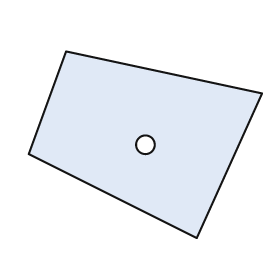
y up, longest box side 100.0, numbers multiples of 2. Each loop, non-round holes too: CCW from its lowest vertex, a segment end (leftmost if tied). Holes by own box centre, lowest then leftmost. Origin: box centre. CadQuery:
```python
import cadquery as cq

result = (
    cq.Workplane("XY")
    .moveTo(22.0, -40.0)
    .lineTo(50.0, 22.0)
    .lineTo(-34.0, 40.0)
    .lineTo(-50.0, -4.0)
    .close()
    .moveTo(0.0, 0.0)
    .circle(4.0)
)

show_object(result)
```